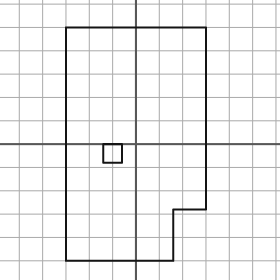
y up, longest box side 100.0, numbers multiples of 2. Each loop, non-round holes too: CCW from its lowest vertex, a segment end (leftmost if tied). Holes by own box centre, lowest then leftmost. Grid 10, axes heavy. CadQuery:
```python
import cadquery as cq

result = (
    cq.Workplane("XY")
    .moveTo(-30.0, -50.0)
    .lineTo(16.0, -50.0)
    .lineTo(16.0, -28.0)
    .lineTo(30.0, -28.0)
    .lineTo(30.0, 50.0)
    .lineTo(-30.0, 50.0)
    .close()
    .moveTo(-14.0, -8.0)
    .lineTo(-6.0, -8.0)
    .lineTo(-6.0, 0.0)
    .lineTo(-14.0, 0.0)
    .close()
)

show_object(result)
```